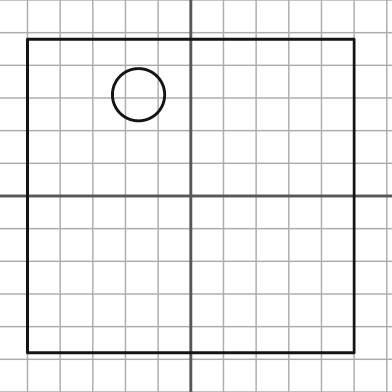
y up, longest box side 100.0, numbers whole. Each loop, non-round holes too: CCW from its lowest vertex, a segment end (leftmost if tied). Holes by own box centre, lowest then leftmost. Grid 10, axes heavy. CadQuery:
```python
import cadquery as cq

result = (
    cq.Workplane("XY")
    .moveTo(-50.0, -48.0)
    .lineTo(50.0, -48.0)
    .lineTo(50.0, 48.0)
    .lineTo(-50.0, 48.0)
    .close()
    .moveTo(-16.0, 31.0)
    .circle(8.0)
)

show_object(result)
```